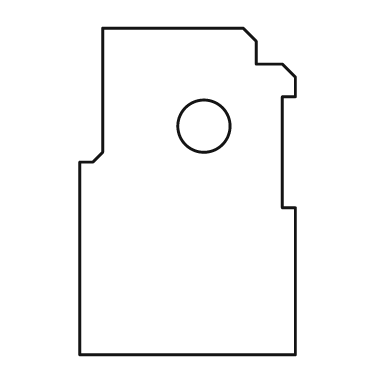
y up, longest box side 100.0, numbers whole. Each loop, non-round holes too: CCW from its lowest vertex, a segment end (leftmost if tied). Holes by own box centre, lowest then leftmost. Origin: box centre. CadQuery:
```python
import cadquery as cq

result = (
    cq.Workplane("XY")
    .moveTo(-33.0, -50.0)
    .lineTo(33.0, -50.0)
    .lineTo(33.0, -5.0)
    .lineTo(29.0, -5.0)
    .lineTo(29.0, 29.0)
    .lineTo(33.0, 29.0)
    .lineTo(33.0, 35.0)
    .lineTo(29.0, 39.0)
    .lineTo(21.0, 39.0)
    .lineTo(21.0, 46.0)
    .lineTo(17.0, 50.0)
    .lineTo(-26.0, 50.0)
    .lineTo(-26.0, 12.0)
    .lineTo(-29.0, 9.0)
    .lineTo(-33.0, 9.0)
    .close()
    .moveTo(5.0, 20.0)
    .circle(8.0)
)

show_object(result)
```